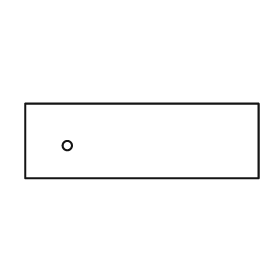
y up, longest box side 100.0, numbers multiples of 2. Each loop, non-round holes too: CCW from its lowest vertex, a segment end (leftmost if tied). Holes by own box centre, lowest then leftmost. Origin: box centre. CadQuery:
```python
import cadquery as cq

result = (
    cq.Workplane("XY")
    .moveTo(-50.0, -16.0)
    .lineTo(50.0, -16.0)
    .lineTo(50.0, 16.0)
    .lineTo(-50.0, 16.0)
    .close()
    .moveTo(-32.0, -2.0)
    .circle(2.0)
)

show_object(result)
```